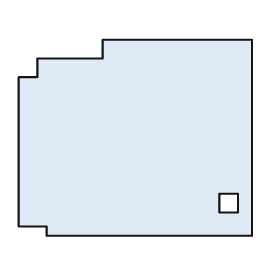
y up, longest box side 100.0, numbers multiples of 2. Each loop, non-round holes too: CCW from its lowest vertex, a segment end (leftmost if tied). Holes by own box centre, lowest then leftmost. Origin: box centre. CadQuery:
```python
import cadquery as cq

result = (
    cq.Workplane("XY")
    .moveTo(-38.0, -42.0)
    .lineTo(50.0, -42.0)
    .lineTo(50.0, 42.0)
    .lineTo(-14.0, 42.0)
    .lineTo(-14.0, 34.0)
    .lineTo(-42.0, 34.0)
    .lineTo(-42.0, 26.0)
    .lineTo(-50.0, 26.0)
    .lineTo(-50.0, -38.0)
    .lineTo(-38.0, -38.0)
    .close()
    .moveTo(36.0, -32.0)
    .lineTo(44.0, -32.0)
    .lineTo(44.0, -24.0)
    .lineTo(36.0, -24.0)
    .close()
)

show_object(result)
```